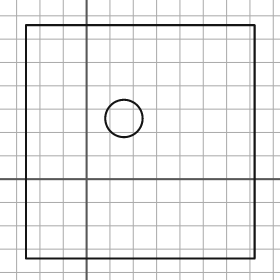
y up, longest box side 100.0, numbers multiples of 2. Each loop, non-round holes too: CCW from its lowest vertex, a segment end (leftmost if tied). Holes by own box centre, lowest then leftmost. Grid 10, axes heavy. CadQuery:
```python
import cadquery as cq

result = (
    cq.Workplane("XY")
    .moveTo(-26.0, -34.0)
    .lineTo(72.0, -34.0)
    .lineTo(72.0, 66.0)
    .lineTo(-26.0, 66.0)
    .close()
    .moveTo(16.0, 26.0)
    .circle(8.0)
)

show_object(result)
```